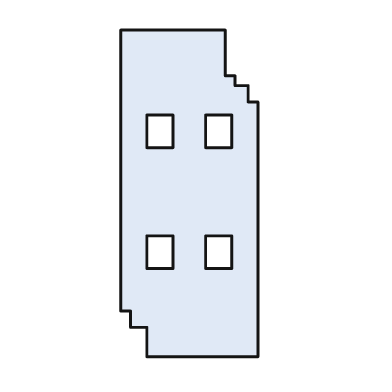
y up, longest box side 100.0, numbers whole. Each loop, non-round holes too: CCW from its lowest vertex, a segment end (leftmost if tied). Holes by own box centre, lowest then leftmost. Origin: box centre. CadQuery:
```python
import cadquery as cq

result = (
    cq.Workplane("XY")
    .moveTo(-13.0, -50.0)
    .lineTo(21.0, -50.0)
    .lineTo(21.0, 28.0)
    .lineTo(18.0, 28.0)
    .lineTo(18.0, 33.0)
    .lineTo(14.0, 33.0)
    .lineTo(14.0, 36.0)
    .lineTo(11.0, 36.0)
    .lineTo(11.0, 50.0)
    .lineTo(-21.0, 50.0)
    .lineTo(-21.0, -36.0)
    .lineTo(-18.0, -36.0)
    .lineTo(-18.0, -41.0)
    .lineTo(-13.0, -41.0)
    .close()
    .moveTo(-13.0, -23.0)
    .lineTo(-5.0, -23.0)
    .lineTo(-5.0, -13.0)
    .lineTo(-13.0, -13.0)
    .close()
    .moveTo(5.0, -23.0)
    .lineTo(13.0, -23.0)
    .lineTo(13.0, -13.0)
    .lineTo(5.0, -13.0)
    .close()
    .moveTo(-13.0, 14.0)
    .lineTo(-5.0, 14.0)
    .lineTo(-5.0, 24.0)
    .lineTo(-13.0, 24.0)
    .close()
    .moveTo(5.0, 14.0)
    .lineTo(13.0, 14.0)
    .lineTo(13.0, 24.0)
    .lineTo(5.0, 24.0)
    .close()
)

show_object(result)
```